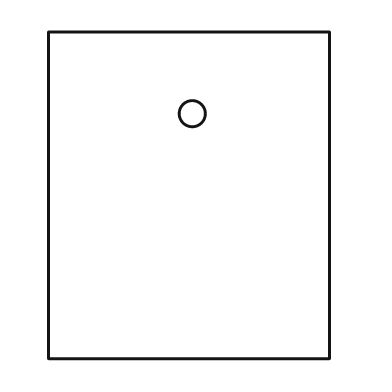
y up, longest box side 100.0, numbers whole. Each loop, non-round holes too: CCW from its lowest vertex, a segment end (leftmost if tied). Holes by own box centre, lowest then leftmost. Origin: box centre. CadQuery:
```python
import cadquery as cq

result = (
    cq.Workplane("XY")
    .moveTo(-43.0, -50.0)
    .lineTo(43.0, -50.0)
    .lineTo(43.0, 50.0)
    .lineTo(-43.0, 50.0)
    .close()
    .moveTo(1.0, 25.0)
    .circle(4.0)
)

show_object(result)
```